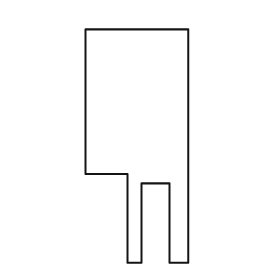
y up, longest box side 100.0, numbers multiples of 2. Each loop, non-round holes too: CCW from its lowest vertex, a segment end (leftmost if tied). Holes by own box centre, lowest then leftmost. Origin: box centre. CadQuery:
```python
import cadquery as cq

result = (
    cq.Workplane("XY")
    .moveTo(-4.0, -50.0)
    .lineTo(2.0, -50.0)
    .lineTo(2.0, -16.0)
    .lineTo(14.0, -16.0)
    .lineTo(14.0, -50.0)
    .lineTo(22.0, -50.0)
    .lineTo(22.0, 50.0)
    .lineTo(-22.0, 50.0)
    .lineTo(-22.0, -12.0)
    .lineTo(-4.0, -12.0)
    .close()
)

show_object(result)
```